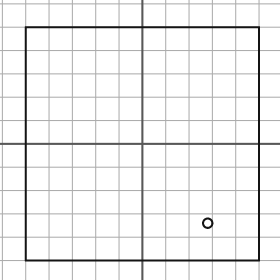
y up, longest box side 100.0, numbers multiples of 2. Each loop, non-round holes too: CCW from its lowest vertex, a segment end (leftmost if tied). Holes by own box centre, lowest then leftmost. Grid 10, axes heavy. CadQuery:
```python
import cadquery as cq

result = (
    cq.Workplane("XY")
    .moveTo(-50.0, -50.0)
    .lineTo(50.0, -50.0)
    .lineTo(50.0, 50.0)
    .lineTo(-50.0, 50.0)
    .close()
    .moveTo(28.0, -34.0)
    .circle(2.0)
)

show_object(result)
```